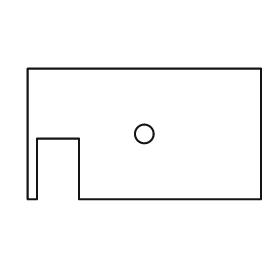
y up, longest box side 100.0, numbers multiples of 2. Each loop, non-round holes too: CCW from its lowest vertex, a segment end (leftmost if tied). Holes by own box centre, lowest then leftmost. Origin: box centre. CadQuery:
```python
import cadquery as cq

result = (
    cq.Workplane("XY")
    .moveTo(-50.0, -28.0)
    .lineTo(-46.0, -28.0)
    .lineTo(-46.0, -2.0)
    .lineTo(-28.0, -2.0)
    .lineTo(-28.0, -28.0)
    .lineTo(50.0, -28.0)
    .lineTo(50.0, 28.0)
    .lineTo(-50.0, 28.0)
    .close()
    .moveTo(0.0, 0.0)
    .circle(4.0)
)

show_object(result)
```